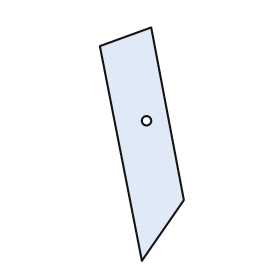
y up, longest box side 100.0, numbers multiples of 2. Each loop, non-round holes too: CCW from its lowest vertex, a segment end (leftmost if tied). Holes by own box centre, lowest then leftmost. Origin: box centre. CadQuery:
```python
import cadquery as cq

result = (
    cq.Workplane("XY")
    .moveTo(0.0, -50.0)
    .lineTo(18.0, -24.0)
    .lineTo(4.0, 50.0)
    .lineTo(-18.0, 42.0)
    .close()
    .moveTo(2.0, 10.0)
    .circle(2.0)
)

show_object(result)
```